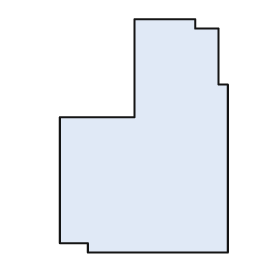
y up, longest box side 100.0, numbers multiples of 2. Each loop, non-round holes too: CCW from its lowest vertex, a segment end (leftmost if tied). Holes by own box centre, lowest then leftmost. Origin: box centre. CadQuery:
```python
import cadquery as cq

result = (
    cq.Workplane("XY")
    .moveTo(-24.0, -50.0)
    .lineTo(36.0, -50.0)
    .lineTo(36.0, 22.0)
    .lineTo(32.0, 22.0)
    .lineTo(32.0, 46.0)
    .lineTo(22.0, 46.0)
    .lineTo(22.0, 50.0)
    .lineTo(-4.0, 50.0)
    .lineTo(-4.0, 8.0)
    .lineTo(-36.0, 8.0)
    .lineTo(-36.0, -46.0)
    .lineTo(-24.0, -46.0)
    .close()
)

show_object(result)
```